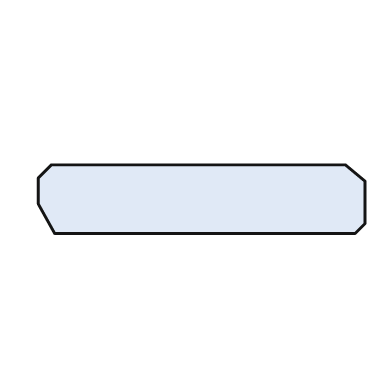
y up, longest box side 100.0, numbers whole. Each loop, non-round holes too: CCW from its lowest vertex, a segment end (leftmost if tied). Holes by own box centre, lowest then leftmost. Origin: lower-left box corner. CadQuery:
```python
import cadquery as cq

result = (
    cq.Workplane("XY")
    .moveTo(5.0, 0.0)
    .lineTo(97.0, 0.0)
    .lineTo(100.0, 3.0)
    .lineTo(100.0, 16.0)
    .lineTo(94.0, 21.0)
    .lineTo(4.0, 21.0)
    .lineTo(0.0, 17.0)
    .lineTo(0.0, 9.0)
    .close()
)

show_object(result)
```